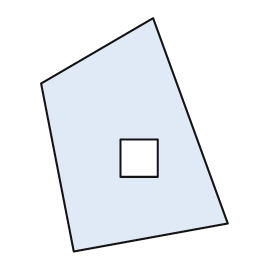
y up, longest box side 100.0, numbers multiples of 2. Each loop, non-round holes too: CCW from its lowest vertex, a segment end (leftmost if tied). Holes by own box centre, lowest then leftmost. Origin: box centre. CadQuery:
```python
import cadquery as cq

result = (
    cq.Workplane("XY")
    .moveTo(-26.0, -50.0)
    .lineTo(40.0, -38.0)
    .lineTo(8.0, 50.0)
    .lineTo(-40.0, 22.0)
    .close()
    .moveTo(-6.0, -18.0)
    .lineTo(10.0, -18.0)
    .lineTo(10.0, -2.0)
    .lineTo(-6.0, -2.0)
    .close()
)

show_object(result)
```